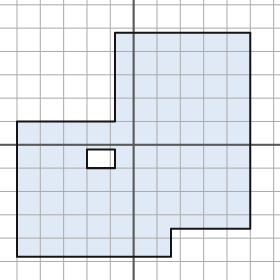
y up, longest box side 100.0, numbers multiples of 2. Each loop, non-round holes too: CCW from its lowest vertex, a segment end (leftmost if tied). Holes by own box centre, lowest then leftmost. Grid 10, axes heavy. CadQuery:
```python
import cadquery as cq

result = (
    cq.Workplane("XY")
    .moveTo(-50.0, -48.0)
    .lineTo(16.0, -48.0)
    .lineTo(16.0, -36.0)
    .lineTo(50.0, -36.0)
    .lineTo(50.0, 48.0)
    .lineTo(-8.0, 48.0)
    .lineTo(-8.0, 10.0)
    .lineTo(-50.0, 10.0)
    .close()
    .moveTo(-20.0, -10.0)
    .lineTo(-8.0, -10.0)
    .lineTo(-8.0, -2.0)
    .lineTo(-20.0, -2.0)
    .close()
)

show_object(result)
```